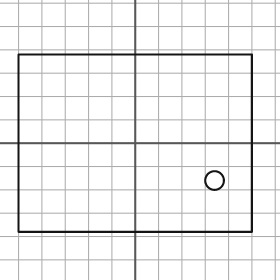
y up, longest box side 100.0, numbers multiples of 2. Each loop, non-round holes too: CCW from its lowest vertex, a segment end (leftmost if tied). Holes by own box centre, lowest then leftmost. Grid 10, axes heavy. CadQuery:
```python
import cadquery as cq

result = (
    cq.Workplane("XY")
    .moveTo(-50.0, -38.0)
    .lineTo(50.0, -38.0)
    .lineTo(50.0, 38.0)
    .lineTo(-50.0, 38.0)
    .close()
    .moveTo(34.0, -16.0)
    .circle(4.0)
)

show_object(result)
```